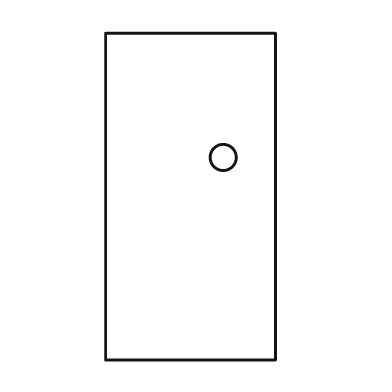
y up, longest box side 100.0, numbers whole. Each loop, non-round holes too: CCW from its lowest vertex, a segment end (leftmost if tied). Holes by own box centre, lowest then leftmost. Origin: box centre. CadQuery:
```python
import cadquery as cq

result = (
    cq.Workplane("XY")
    .moveTo(-26.0, -50.0)
    .lineTo(26.0, -50.0)
    .lineTo(26.0, 50.0)
    .lineTo(-26.0, 50.0)
    .close()
    .moveTo(10.0, 12.0)
    .circle(4.0)
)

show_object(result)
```